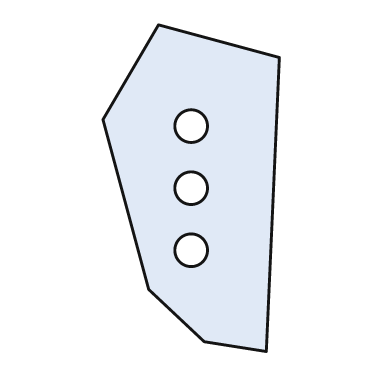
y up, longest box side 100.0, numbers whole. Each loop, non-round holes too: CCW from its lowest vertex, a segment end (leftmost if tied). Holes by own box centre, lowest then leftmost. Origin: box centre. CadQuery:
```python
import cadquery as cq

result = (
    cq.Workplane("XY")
    .moveTo(23.0, -50.0)
    .lineTo(27.0, 40.0)
    .lineTo(-10.0, 50.0)
    .lineTo(-27.0, 21.0)
    .lineTo(-13.0, -31.0)
    .lineTo(4.0, -47.0)
    .close()
    .moveTo(0.0, -19.0)
    .circle(5.0)
    .moveTo(0.0, 0.0)
    .circle(5.0)
    .moveTo(0.0, 19.0)
    .circle(5.0)
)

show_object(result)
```